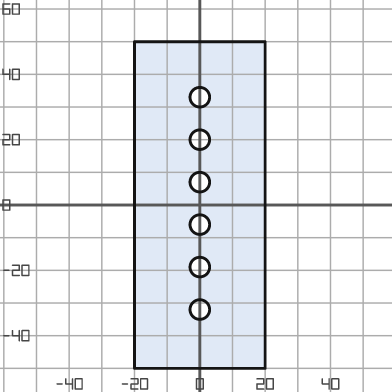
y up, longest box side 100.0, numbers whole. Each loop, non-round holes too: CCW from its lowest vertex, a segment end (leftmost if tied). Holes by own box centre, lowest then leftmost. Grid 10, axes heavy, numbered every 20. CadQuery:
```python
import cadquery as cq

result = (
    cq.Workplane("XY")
    .moveTo(-20.0, -50.0)
    .lineTo(20.0, -50.0)
    .lineTo(20.0, 50.0)
    .lineTo(-20.0, 50.0)
    .close()
    .moveTo(0.0, -32.0)
    .circle(3.0)
    .moveTo(0.0, -19.0)
    .circle(3.0)
    .moveTo(0.0, -6.0)
    .circle(3.0)
    .moveTo(0.0, 7.0)
    .circle(3.0)
    .moveTo(0.0, 20.0)
    .circle(3.0)
    .moveTo(0.0, 33.0)
    .circle(3.0)
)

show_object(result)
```